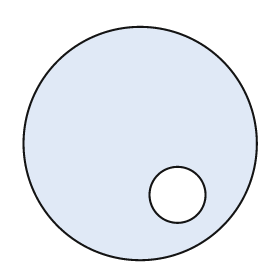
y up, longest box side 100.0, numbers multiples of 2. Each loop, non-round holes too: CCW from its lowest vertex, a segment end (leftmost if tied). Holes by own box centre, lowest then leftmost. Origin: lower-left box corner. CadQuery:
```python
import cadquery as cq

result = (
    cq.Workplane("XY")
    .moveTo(50.0, 50.0)
    .circle(50.0)
    .moveTo(66.0, 28.0)
    .circle(12.0)
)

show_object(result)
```